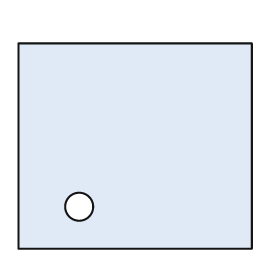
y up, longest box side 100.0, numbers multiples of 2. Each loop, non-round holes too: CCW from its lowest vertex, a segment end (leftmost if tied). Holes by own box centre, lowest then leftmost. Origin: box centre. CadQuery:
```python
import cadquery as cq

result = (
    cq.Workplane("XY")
    .moveTo(-50.0, -44.0)
    .lineTo(50.0, -44.0)
    .lineTo(50.0, 44.0)
    .lineTo(-50.0, 44.0)
    .close()
    .moveTo(-24.0, -26.0)
    .circle(6.0)
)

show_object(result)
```